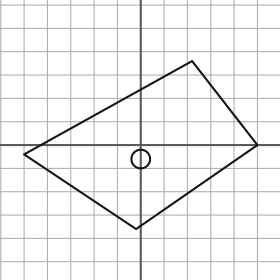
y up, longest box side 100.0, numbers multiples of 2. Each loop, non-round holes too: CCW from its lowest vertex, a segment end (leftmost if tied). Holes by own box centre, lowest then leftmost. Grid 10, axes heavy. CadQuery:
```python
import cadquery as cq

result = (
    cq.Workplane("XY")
    .moveTo(-2.0, -36.0)
    .lineTo(50.0, 0.0)
    .lineTo(22.0, 36.0)
    .lineTo(-50.0, -4.0)
    .close()
    .moveTo(0.0, -6.0)
    .circle(4.0)
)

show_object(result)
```